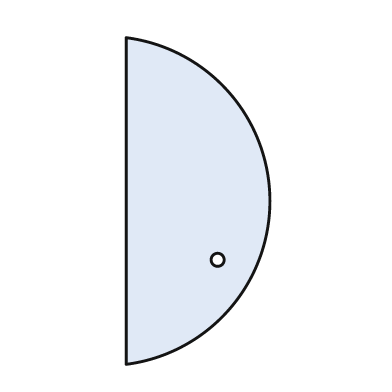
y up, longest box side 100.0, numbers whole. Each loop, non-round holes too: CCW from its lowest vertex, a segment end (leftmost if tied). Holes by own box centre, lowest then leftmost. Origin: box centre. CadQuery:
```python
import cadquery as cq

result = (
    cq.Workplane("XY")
    .moveTo(-22.0, -50.0)
    .threePointArc((22.0, 0.0), (-22.0, 50.0))
    .close()
    .moveTo(6.0, -18.0)
    .circle(2.0)
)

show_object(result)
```